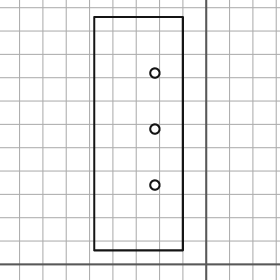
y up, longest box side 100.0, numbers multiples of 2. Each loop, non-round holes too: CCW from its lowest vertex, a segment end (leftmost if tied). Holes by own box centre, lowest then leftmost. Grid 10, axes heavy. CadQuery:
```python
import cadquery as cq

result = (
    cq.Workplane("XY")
    .moveTo(-48.0, 6.0)
    .lineTo(-10.0, 6.0)
    .lineTo(-10.0, 106.0)
    .lineTo(-48.0, 106.0)
    .close()
    .moveTo(-22.0, 34.0)
    .circle(2.0)
    .moveTo(-22.0, 58.0)
    .circle(2.0)
    .moveTo(-22.0, 82.0)
    .circle(2.0)
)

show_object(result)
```